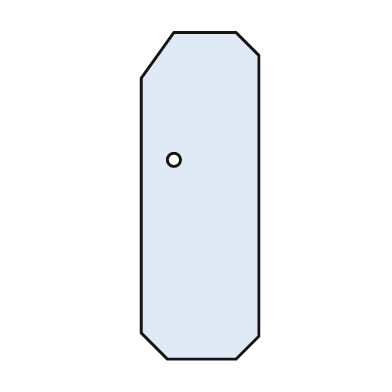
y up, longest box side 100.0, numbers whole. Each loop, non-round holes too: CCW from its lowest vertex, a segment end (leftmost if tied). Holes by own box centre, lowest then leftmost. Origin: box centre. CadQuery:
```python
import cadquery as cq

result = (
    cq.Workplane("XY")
    .moveTo(-10.0, -50.0)
    .lineTo(11.0, -50.0)
    .lineTo(18.0, -43.0)
    .lineTo(18.0, 43.0)
    .lineTo(11.0, 50.0)
    .lineTo(-8.0, 50.0)
    .lineTo(-18.0, 36.0)
    .lineTo(-18.0, -42.0)
    .close()
    .moveTo(-8.0, 11.0)
    .circle(2.0)
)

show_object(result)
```